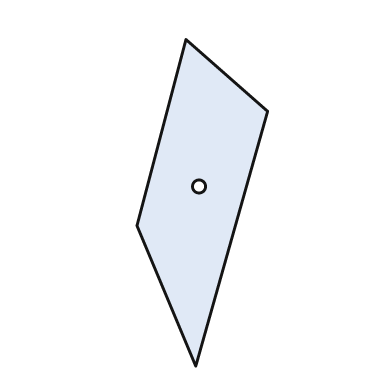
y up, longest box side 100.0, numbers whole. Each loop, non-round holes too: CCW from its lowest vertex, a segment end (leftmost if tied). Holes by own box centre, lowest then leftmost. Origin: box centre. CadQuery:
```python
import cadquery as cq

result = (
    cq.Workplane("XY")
    .moveTo(-2.0, -50.0)
    .lineTo(20.0, 28.0)
    .lineTo(-5.0, 50.0)
    .lineTo(-20.0, -7.0)
    .close()
    .moveTo(-1.0, 5.0)
    .circle(2.0)
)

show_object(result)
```